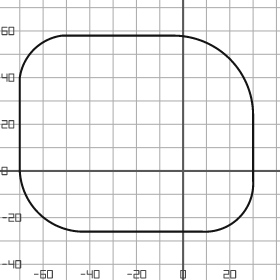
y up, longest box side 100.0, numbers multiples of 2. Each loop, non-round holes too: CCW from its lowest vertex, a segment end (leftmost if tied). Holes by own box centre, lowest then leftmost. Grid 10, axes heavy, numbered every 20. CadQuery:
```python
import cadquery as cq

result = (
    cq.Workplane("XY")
    .moveTo(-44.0, -26.0)
    .lineTo(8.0, -26.0)
    .threePointArc((24.0, -20.0), (30.0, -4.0))
    .lineTo(30.0, 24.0)
    .threePointArc((20.0, 48.0), (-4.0, 58.0))
    .lineTo(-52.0, 58.0)
    .threePointArc((-64.0, 52.0), (-70.0, 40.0))
    .lineTo(-70.0, 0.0)
    .threePointArc((-62.0, -18.0), (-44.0, -26.0))
    .close()
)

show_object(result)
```